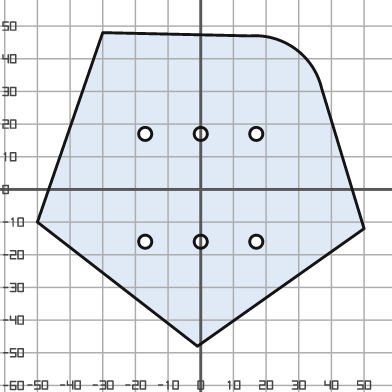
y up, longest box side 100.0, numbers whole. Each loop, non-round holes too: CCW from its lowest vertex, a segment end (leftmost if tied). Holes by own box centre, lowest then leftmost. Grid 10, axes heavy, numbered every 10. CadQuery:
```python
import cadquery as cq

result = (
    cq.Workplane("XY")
    .moveTo(-1.0, -48.0)
    .lineTo(50.0, -12.0)
    .lineTo(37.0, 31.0)
    .threePointArc((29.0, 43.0), (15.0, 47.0))
    .lineTo(-30.0, 48.0)
    .lineTo(-50.0, -10.0)
    .close()
    .moveTo(-17.0, -16.0)
    .circle(2.0)
    .moveTo(0.0, -16.0)
    .circle(2.0)
    .moveTo(17.0, -16.0)
    .circle(2.0)
    .moveTo(-17.0, 17.0)
    .circle(2.0)
    .moveTo(0.0, 17.0)
    .circle(2.0)
    .moveTo(17.0, 17.0)
    .circle(2.0)
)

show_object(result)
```